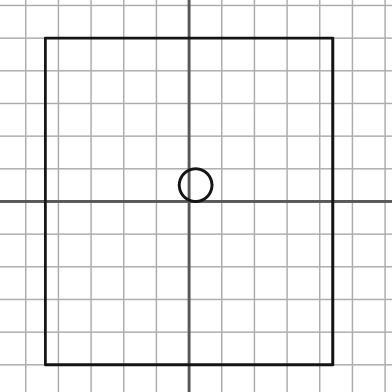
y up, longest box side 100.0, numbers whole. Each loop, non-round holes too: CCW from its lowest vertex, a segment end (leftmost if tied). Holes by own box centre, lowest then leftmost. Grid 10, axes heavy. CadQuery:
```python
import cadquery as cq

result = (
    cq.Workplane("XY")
    .moveTo(-44.0, -50.0)
    .lineTo(44.0, -50.0)
    .lineTo(44.0, 50.0)
    .lineTo(-44.0, 50.0)
    .close()
    .moveTo(2.0, 5.0)
    .circle(5.0)
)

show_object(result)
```